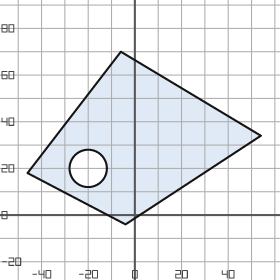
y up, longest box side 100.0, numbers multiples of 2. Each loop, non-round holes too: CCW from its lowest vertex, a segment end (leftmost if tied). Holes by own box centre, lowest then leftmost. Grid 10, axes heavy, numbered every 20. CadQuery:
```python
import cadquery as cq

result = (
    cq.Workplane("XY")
    .moveTo(-4.0, -4.0)
    .lineTo(54.0, 34.0)
    .lineTo(-6.0, 70.0)
    .lineTo(-46.0, 18.0)
    .close()
    .moveTo(-20.0, 20.0)
    .circle(8.0)
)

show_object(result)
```